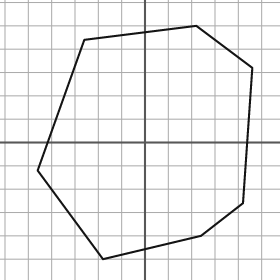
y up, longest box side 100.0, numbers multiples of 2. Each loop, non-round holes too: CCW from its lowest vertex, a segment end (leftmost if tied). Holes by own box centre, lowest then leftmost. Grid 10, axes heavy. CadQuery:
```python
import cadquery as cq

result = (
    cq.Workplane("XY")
    .moveTo(-18.0, -50.0)
    .lineTo(24.0, -40.0)
    .lineTo(42.0, -26.0)
    .lineTo(46.0, 32.0)
    .lineTo(22.0, 50.0)
    .lineTo(-26.0, 44.0)
    .lineTo(-46.0, -12.0)
    .close()
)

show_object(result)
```